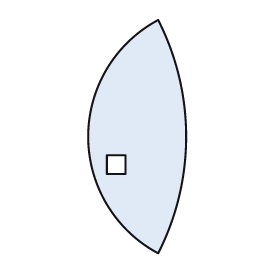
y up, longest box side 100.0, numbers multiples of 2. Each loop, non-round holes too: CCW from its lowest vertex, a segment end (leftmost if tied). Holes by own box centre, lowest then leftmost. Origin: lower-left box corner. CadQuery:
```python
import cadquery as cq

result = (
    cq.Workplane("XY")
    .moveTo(30.0, 0.0)
    .threePointArc((42.0, 50.0), (30.0, 100.0))
    .threePointArc((0.0, 50.0), (30.0, 0.0))
    .close()
    .moveTo(8.0, 34.0)
    .lineTo(16.0, 34.0)
    .lineTo(16.0, 42.0)
    .lineTo(8.0, 42.0)
    .close()
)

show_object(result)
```